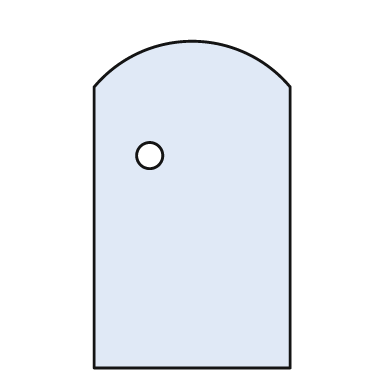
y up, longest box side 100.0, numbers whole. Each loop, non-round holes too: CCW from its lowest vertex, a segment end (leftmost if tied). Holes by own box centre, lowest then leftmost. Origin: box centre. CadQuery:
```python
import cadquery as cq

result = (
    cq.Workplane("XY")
    .moveTo(-30.0, -50.0)
    .lineTo(30.0, -50.0)
    .lineTo(30.0, 36.0)
    .threePointArc((0.0, 50.0), (-30.0, 36.0))
    .close()
    .moveTo(-13.0, 15.0)
    .circle(4.0)
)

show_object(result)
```